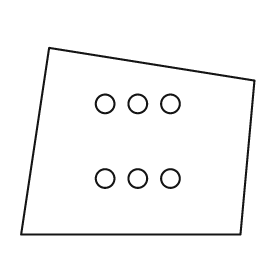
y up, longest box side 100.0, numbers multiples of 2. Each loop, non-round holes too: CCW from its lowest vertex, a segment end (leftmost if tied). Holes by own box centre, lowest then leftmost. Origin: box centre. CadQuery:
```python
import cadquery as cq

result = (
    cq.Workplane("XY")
    .moveTo(-50.0, -40.0)
    .lineTo(44.0, -40.0)
    .lineTo(50.0, 26.0)
    .lineTo(-38.0, 40.0)
    .close()
    .moveTo(-14.0, -16.0)
    .circle(4.0)
    .moveTo(0.0, -16.0)
    .circle(4.0)
    .moveTo(14.0, -16.0)
    .circle(4.0)
    .moveTo(-14.0, 16.0)
    .circle(4.0)
    .moveTo(0.0, 16.0)
    .circle(4.0)
    .moveTo(14.0, 16.0)
    .circle(4.0)
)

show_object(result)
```